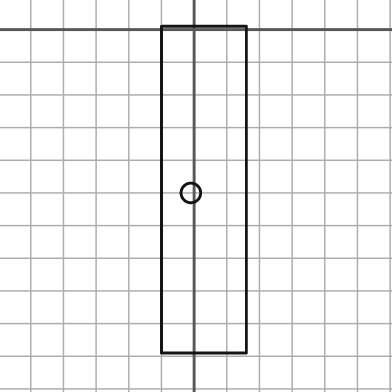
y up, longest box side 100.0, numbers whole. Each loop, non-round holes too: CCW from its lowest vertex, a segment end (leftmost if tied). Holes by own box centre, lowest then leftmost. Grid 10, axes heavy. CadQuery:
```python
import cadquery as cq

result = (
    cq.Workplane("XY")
    .moveTo(-10.0, -99.0)
    .lineTo(16.0, -99.0)
    .lineTo(16.0, 1.0)
    .lineTo(-10.0, 1.0)
    .close()
    .moveTo(-1.0, -50.0)
    .circle(3.0)
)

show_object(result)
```